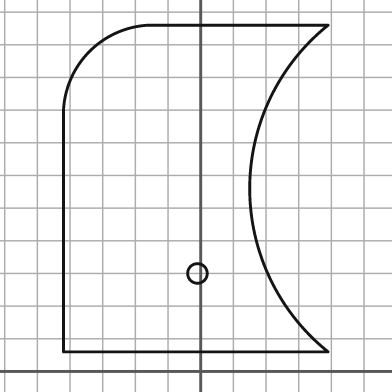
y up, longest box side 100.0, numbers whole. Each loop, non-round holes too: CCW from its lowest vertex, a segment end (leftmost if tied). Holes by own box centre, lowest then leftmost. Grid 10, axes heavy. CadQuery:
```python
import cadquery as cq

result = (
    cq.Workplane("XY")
    .moveTo(-42.0, 6.0)
    .lineTo(39.0, 6.0)
    .threePointArc((15.0, 56.0), (39.0, 106.0))
    .lineTo(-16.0, 106.0)
    .threePointArc((-34.0, 98.0), (-42.0, 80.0))
    .close()
    .moveTo(-1.0, 30.0)
    .circle(3.0)
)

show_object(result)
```